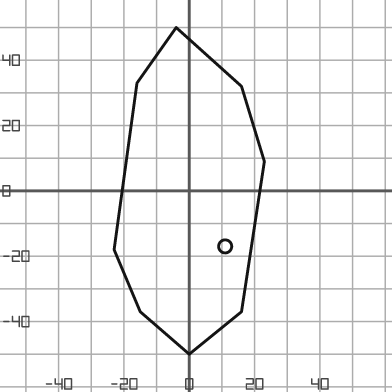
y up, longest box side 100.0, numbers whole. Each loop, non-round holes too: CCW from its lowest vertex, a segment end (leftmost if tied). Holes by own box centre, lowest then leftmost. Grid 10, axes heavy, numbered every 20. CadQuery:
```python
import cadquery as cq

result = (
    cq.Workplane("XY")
    .moveTo(0.0, -50.0)
    .lineTo(16.0, -37.0)
    .lineTo(23.0, 9.0)
    .lineTo(16.0, 32.0)
    .lineTo(-4.0, 50.0)
    .lineTo(-16.0, 33.0)
    .lineTo(-23.0, -18.0)
    .lineTo(-15.0, -37.0)
    .close()
    .moveTo(11.0, -17.0)
    .circle(2.0)
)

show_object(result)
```